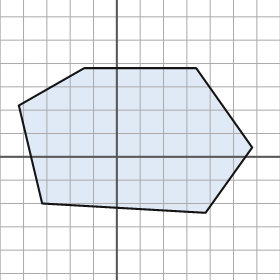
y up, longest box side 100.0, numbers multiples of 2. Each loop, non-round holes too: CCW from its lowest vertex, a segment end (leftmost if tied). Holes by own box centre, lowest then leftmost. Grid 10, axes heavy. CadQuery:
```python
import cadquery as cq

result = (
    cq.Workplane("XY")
    .moveTo(38.0, -24.0)
    .lineTo(58.0, 4.0)
    .lineTo(34.0, 38.0)
    .lineTo(-14.0, 38.0)
    .lineTo(-42.0, 22.0)
    .lineTo(-32.0, -20.0)
    .close()
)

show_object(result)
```